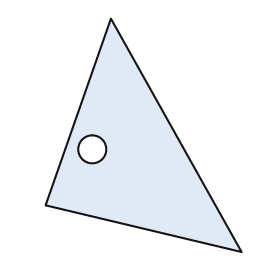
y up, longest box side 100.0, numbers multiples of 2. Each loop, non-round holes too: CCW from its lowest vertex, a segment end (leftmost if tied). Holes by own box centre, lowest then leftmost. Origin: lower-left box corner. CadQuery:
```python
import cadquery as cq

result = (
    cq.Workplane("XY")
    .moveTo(84.0, 0.0)
    .lineTo(28.0, 100.0)
    .lineTo(0.0, 20.0)
    .close()
    .moveTo(20.0, 44.0)
    .circle(6.0)
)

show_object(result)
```